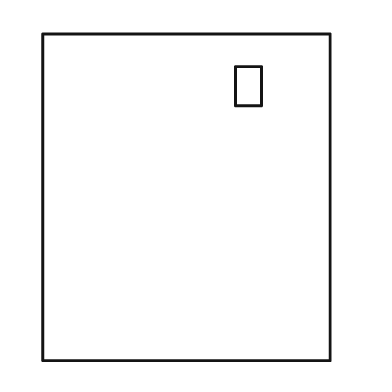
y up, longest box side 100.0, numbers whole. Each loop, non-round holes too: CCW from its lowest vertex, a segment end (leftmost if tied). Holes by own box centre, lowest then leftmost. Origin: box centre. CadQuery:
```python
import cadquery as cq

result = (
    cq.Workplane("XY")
    .moveTo(-44.0, -50.0)
    .lineTo(44.0, -50.0)
    .lineTo(44.0, 50.0)
    .lineTo(-44.0, 50.0)
    .close()
    .moveTo(15.0, 28.0)
    .lineTo(23.0, 28.0)
    .lineTo(23.0, 40.0)
    .lineTo(15.0, 40.0)
    .close()
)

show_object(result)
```